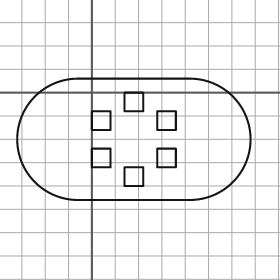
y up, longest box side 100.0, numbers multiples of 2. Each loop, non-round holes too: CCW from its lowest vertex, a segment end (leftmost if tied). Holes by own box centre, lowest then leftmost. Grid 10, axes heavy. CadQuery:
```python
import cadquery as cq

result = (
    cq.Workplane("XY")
    .moveTo(-6.0, -46.0)
    .lineTo(42.0, -46.0)
    .threePointArc((68.0, -20.0), (42.0, 6.0))
    .lineTo(-6.0, 6.0)
    .threePointArc((-32.0, -20.0), (-6.0, -46.0))
    .close()
    .moveTo(14.0, -40.0)
    .lineTo(22.0, -40.0)
    .lineTo(22.0, -32.0)
    .lineTo(14.0, -32.0)
    .close()
    .moveTo(0.0, -32.0)
    .lineTo(8.0, -32.0)
    .lineTo(8.0, -24.0)
    .lineTo(0.0, -24.0)
    .close()
    .moveTo(28.0, -32.0)
    .lineTo(36.0, -32.0)
    .lineTo(36.0, -24.0)
    .lineTo(28.0, -24.0)
    .close()
    .moveTo(0.0, -16.0)
    .lineTo(8.0, -16.0)
    .lineTo(8.0, -8.0)
    .lineTo(0.0, -8.0)
    .close()
    .moveTo(28.0, -16.0)
    .lineTo(36.0, -16.0)
    .lineTo(36.0, -8.0)
    .lineTo(28.0, -8.0)
    .close()
    .moveTo(14.0, -8.0)
    .lineTo(22.0, -8.0)
    .lineTo(22.0, 0.0)
    .lineTo(14.0, 0.0)
    .close()
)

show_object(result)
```